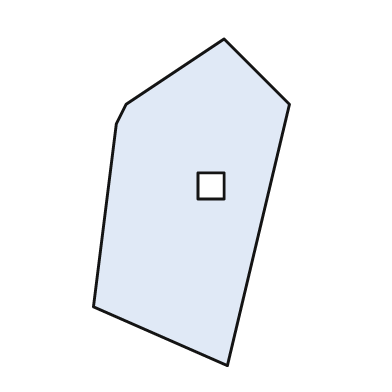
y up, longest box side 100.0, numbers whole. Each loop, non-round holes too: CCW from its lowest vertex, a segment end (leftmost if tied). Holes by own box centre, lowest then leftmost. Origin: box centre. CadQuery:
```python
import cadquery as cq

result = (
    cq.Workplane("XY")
    .moveTo(11.0, -50.0)
    .lineTo(30.0, 30.0)
    .lineTo(10.0, 50.0)
    .lineTo(-20.0, 30.0)
    .lineTo(-23.0, 24.0)
    .lineTo(-30.0, -32.0)
    .close()
    .moveTo(2.0, 1.0)
    .lineTo(10.0, 1.0)
    .lineTo(10.0, 9.0)
    .lineTo(2.0, 9.0)
    .close()
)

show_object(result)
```